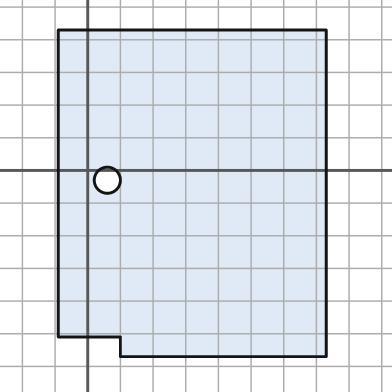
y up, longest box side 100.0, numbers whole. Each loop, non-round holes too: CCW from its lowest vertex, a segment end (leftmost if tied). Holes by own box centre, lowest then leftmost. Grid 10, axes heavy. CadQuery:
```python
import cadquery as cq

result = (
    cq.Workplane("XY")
    .moveTo(10.0, -57.0)
    .lineTo(73.0, -57.0)
    .lineTo(73.0, 43.0)
    .lineTo(-9.0, 43.0)
    .lineTo(-9.0, -51.0)
    .lineTo(10.0, -51.0)
    .close()
    .moveTo(6.0, -3.0)
    .circle(4.0)
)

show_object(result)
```